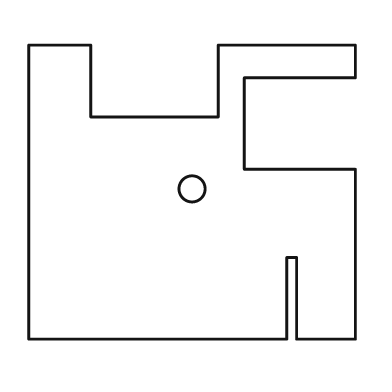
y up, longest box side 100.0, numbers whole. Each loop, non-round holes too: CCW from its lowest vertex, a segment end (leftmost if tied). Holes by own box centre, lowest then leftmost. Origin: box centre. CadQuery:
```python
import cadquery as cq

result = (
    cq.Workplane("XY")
    .moveTo(-50.0, -45.0)
    .lineTo(29.0, -45.0)
    .lineTo(29.0, -20.0)
    .lineTo(32.0, -20.0)
    .lineTo(32.0, -45.0)
    .lineTo(50.0, -45.0)
    .lineTo(50.0, 7.0)
    .lineTo(16.0, 7.0)
    .lineTo(16.0, 35.0)
    .lineTo(50.0, 35.0)
    .lineTo(50.0, 45.0)
    .lineTo(8.0, 45.0)
    .lineTo(8.0, 23.0)
    .lineTo(-31.0, 23.0)
    .lineTo(-31.0, 45.0)
    .lineTo(-50.0, 45.0)
    .close()
    .moveTo(0.0, 1.0)
    .circle(4.0)
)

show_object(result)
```